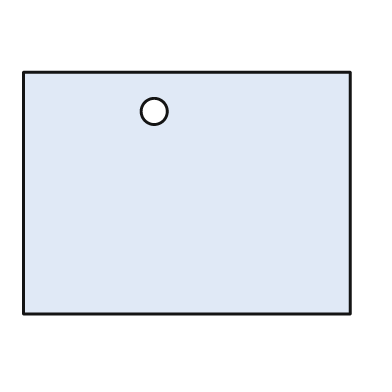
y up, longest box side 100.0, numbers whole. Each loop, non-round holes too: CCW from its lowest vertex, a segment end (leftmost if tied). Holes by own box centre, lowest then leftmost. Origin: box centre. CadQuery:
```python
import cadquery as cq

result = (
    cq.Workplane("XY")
    .moveTo(-50.0, -37.0)
    .lineTo(50.0, -37.0)
    .lineTo(50.0, 37.0)
    .lineTo(-50.0, 37.0)
    .close()
    .moveTo(-10.0, 25.0)
    .circle(4.0)
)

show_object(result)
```